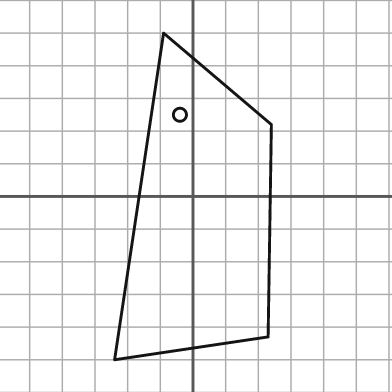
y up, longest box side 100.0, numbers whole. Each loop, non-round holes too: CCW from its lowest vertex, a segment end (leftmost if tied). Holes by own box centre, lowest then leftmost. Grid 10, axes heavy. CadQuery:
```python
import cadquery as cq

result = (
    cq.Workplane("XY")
    .moveTo(-24.0, -50.0)
    .lineTo(23.0, -43.0)
    .lineTo(24.0, 22.0)
    .lineTo(-9.0, 50.0)
    .close()
    .moveTo(-4.0, 25.0)
    .circle(2.0)
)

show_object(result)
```